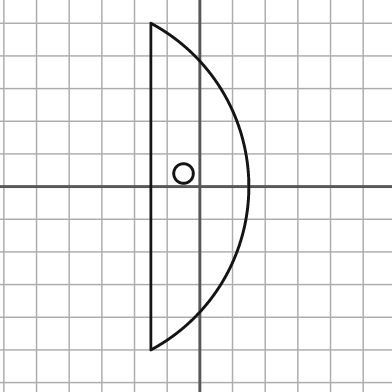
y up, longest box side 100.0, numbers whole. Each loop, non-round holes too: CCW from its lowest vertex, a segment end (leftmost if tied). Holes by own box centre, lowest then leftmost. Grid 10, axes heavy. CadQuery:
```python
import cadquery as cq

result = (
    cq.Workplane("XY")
    .moveTo(-15.0, -50.0)
    .threePointArc((15.0, 0.0), (-15.0, 50.0))
    .close()
    .moveTo(-5.0, 4.0)
    .circle(3.0)
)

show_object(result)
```